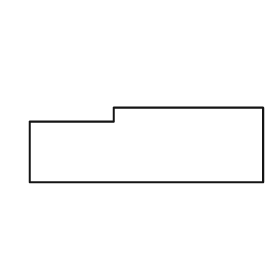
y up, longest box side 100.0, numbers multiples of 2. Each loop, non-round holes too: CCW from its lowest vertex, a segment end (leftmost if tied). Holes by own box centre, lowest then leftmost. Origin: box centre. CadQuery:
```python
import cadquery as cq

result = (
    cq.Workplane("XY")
    .moveTo(-50.0, -16.0)
    .lineTo(50.0, -16.0)
    .lineTo(50.0, 16.0)
    .lineTo(-14.0, 16.0)
    .lineTo(-14.0, 10.0)
    .lineTo(-50.0, 10.0)
    .close()
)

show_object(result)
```